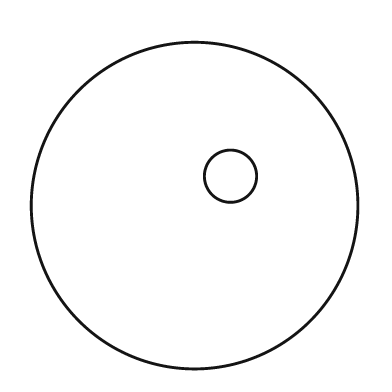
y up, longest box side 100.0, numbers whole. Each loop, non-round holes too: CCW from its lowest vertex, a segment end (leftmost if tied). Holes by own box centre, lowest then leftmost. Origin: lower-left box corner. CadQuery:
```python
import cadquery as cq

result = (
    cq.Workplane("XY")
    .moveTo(50.0, 50.0)
    .circle(50.0)
    .moveTo(61.0, 59.0)
    .circle(8.0)
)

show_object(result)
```